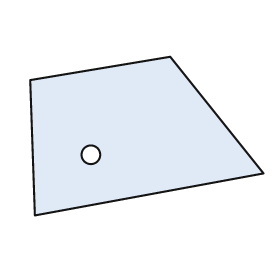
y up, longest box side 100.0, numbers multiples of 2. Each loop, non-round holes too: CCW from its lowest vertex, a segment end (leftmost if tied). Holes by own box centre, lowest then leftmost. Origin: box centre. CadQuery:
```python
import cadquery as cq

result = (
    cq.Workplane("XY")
    .moveTo(-48.0, -34.0)
    .lineTo(50.0, -16.0)
    .lineTo(10.0, 34.0)
    .lineTo(-50.0, 24.0)
    .close()
    .moveTo(-24.0, -8.0)
    .circle(4.0)
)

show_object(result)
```